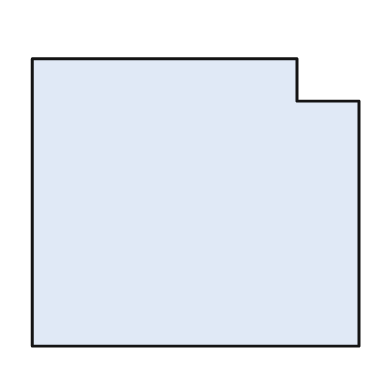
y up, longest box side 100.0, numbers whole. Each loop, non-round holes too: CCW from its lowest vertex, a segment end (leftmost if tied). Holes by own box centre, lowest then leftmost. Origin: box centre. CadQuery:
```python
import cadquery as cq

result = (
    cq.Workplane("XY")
    .moveTo(-50.0, -44.0)
    .lineTo(50.0, -44.0)
    .lineTo(50.0, 31.0)
    .lineTo(31.0, 31.0)
    .lineTo(31.0, 44.0)
    .lineTo(-50.0, 44.0)
    .close()
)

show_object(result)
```